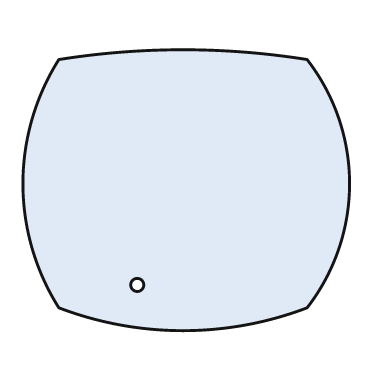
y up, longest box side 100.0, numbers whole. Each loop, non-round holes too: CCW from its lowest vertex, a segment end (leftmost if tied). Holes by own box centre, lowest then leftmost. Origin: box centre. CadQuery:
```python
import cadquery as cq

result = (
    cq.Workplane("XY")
    .moveTo(-39.0, -36.0)
    .threePointArc((-1.0, -43.0), (37.0, -36.0))
    .threePointArc((50.0, 2.0), (37.0, 40.0))
    .threePointArc((-1.0, 43.0), (-39.0, 40.0))
    .threePointArc((-50.0, 2.0), (-39.0, -36.0))
    .close()
    .moveTo(-15.0, -29.0)
    .circle(2.0)
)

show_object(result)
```